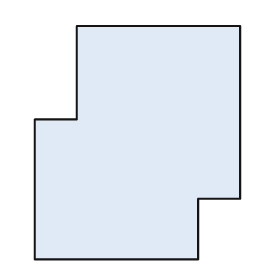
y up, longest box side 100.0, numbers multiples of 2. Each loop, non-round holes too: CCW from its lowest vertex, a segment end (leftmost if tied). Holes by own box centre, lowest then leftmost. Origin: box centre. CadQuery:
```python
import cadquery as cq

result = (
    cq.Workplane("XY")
    .moveTo(-44.0, -50.0)
    .lineTo(26.0, -50.0)
    .lineTo(26.0, -24.0)
    .lineTo(44.0, -24.0)
    .lineTo(44.0, 50.0)
    .lineTo(-26.0, 50.0)
    .lineTo(-26.0, 10.0)
    .lineTo(-44.0, 10.0)
    .close()
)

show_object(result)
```